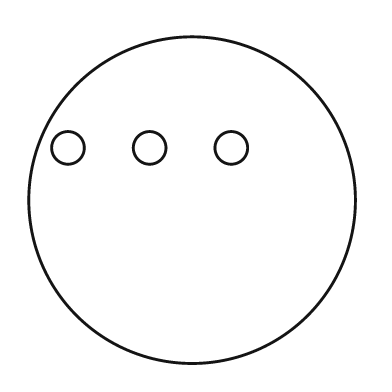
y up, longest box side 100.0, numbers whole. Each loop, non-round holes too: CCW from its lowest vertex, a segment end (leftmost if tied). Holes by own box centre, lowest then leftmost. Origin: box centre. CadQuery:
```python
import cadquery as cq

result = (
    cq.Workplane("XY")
    .moveTo(0.0, 0.0)
    .circle(50.0)
    .moveTo(-38.0, 16.0)
    .circle(5.0)
    .moveTo(-13.0, 16.0)
    .circle(5.0)
    .moveTo(12.0, 16.0)
    .circle(5.0)
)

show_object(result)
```